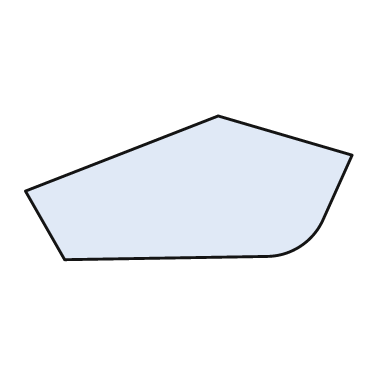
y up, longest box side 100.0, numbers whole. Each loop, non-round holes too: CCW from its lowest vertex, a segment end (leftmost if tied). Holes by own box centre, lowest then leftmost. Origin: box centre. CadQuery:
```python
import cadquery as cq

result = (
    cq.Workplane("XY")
    .moveTo(-38.0, -22.0)
    .lineTo(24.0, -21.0)
    .threePointArc((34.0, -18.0), (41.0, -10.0))
    .lineTo(50.0, 10.0)
    .lineTo(9.0, 22.0)
    .lineTo(-50.0, -1.0)
    .close()
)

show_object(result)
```